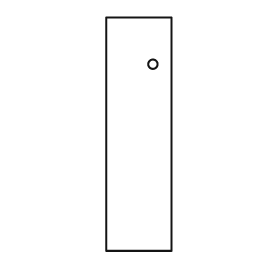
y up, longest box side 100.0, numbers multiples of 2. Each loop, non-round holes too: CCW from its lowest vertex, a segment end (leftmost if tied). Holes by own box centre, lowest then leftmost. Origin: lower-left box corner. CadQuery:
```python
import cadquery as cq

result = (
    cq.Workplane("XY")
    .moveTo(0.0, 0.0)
    .lineTo(28.0, 0.0)
    .lineTo(28.0, 100.0)
    .lineTo(0.0, 100.0)
    .close()
    .moveTo(20.0, 80.0)
    .circle(2.0)
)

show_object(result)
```